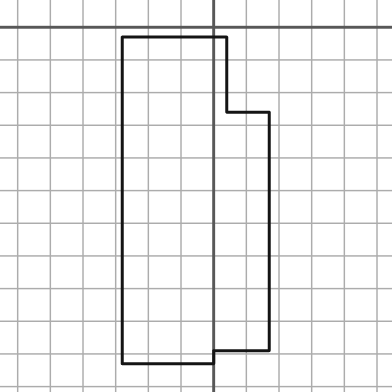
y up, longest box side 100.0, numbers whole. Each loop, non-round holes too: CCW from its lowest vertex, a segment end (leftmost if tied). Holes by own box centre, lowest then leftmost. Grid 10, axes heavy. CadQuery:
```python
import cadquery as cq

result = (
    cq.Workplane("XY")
    .moveTo(-28.0, -103.0)
    .lineTo(0.0, -103.0)
    .lineTo(0.0, -99.0)
    .lineTo(17.0, -99.0)
    .lineTo(17.0, -26.0)
    .lineTo(4.0, -26.0)
    .lineTo(4.0, -3.0)
    .lineTo(-28.0, -3.0)
    .close()
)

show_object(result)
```